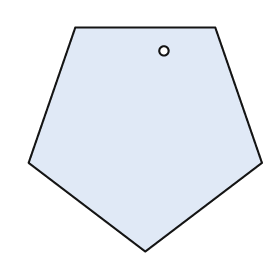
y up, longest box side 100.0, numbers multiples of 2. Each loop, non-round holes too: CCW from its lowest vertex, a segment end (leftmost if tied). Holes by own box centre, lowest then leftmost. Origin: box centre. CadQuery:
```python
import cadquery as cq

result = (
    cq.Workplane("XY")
    .moveTo(0.0, -48.0)
    .lineTo(50.0, -10.0)
    .lineTo(30.0, 48.0)
    .lineTo(-30.0, 48.0)
    .lineTo(-50.0, -10.0)
    .close()
    .moveTo(8.0, 38.0)
    .circle(2.0)
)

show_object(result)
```